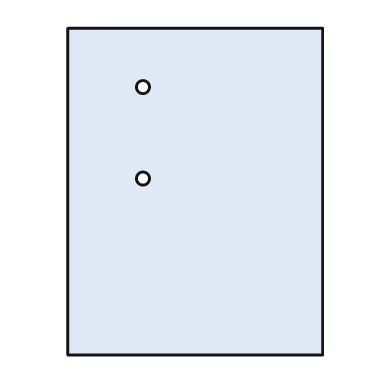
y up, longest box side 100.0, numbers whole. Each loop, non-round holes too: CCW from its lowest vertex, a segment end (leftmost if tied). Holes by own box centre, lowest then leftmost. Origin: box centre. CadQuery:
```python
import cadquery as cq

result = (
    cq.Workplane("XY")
    .moveTo(-39.0, -50.0)
    .lineTo(39.0, -50.0)
    .lineTo(39.0, 50.0)
    .lineTo(-39.0, 50.0)
    .close()
    .moveTo(-16.0, 4.0)
    .circle(2.0)
    .moveTo(-16.0, 32.0)
    .circle(2.0)
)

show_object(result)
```